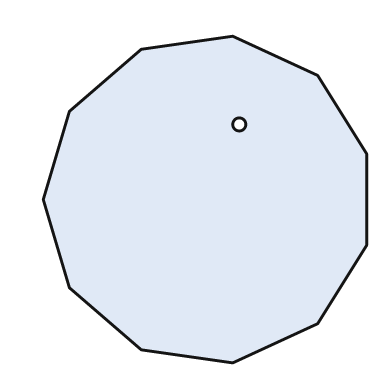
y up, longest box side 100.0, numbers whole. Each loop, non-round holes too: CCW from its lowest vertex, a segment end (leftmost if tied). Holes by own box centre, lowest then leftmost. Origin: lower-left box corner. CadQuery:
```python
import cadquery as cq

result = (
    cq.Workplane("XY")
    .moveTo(58.0, 0.0)
    .lineTo(84.0, 12.0)
    .lineTo(99.0, 36.0)
    .lineTo(99.0, 64.0)
    .lineTo(84.0, 88.0)
    .lineTo(58.0, 100.0)
    .lineTo(30.0, 96.0)
    .lineTo(8.0, 77.0)
    .lineTo(0.0, 50.0)
    .lineTo(8.0, 23.0)
    .lineTo(30.0, 4.0)
    .close()
    .moveTo(60.0, 73.0)
    .circle(2.0)
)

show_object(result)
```